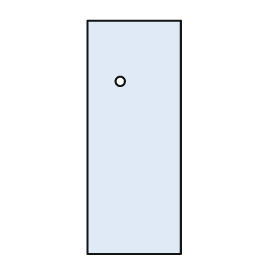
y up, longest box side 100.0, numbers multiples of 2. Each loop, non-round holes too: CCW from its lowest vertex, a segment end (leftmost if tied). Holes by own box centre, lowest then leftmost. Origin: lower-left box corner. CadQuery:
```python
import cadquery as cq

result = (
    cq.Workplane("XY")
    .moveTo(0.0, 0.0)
    .lineTo(40.0, 0.0)
    .lineTo(40.0, 100.0)
    .lineTo(0.0, 100.0)
    .close()
    .moveTo(14.0, 74.0)
    .circle(2.0)
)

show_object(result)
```